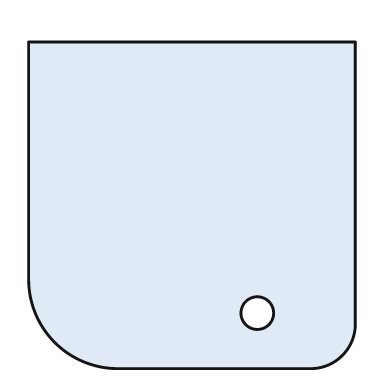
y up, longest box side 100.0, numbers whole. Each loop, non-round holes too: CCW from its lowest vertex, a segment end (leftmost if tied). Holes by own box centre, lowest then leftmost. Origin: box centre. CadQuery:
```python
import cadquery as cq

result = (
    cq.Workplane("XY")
    .moveTo(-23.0, -50.0)
    .lineTo(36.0, -50.0)
    .threePointArc((46.0, -46.0), (50.0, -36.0))
    .lineTo(50.0, 50.0)
    .lineTo(-50.0, 50.0)
    .lineTo(-50.0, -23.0)
    .threePointArc((-42.0, -42.0), (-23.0, -50.0))
    .close()
    .moveTo(20.0, -33.0)
    .circle(5.0)
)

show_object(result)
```